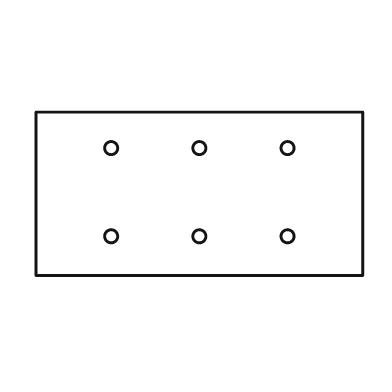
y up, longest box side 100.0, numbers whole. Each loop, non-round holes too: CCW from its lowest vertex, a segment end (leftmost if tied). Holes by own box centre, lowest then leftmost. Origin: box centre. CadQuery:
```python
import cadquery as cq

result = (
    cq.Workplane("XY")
    .moveTo(-50.0, -25.0)
    .lineTo(50.0, -25.0)
    .lineTo(50.0, 25.0)
    .lineTo(-50.0, 25.0)
    .close()
    .moveTo(-27.0, -13.0)
    .circle(2.0)
    .moveTo(0.0, -13.0)
    .circle(2.0)
    .moveTo(27.0, -13.0)
    .circle(2.0)
    .moveTo(-27.0, 14.0)
    .circle(2.0)
    .moveTo(0.0, 14.0)
    .circle(2.0)
    .moveTo(27.0, 14.0)
    .circle(2.0)
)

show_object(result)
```